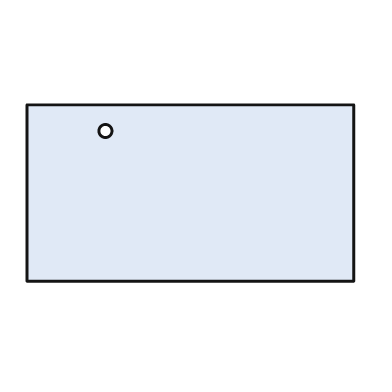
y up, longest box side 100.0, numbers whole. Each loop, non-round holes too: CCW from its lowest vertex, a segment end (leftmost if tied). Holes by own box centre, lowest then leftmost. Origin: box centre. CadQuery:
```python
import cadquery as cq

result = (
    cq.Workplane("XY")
    .moveTo(-50.0, -27.0)
    .lineTo(50.0, -27.0)
    .lineTo(50.0, 27.0)
    .lineTo(-50.0, 27.0)
    .close()
    .moveTo(-26.0, 19.0)
    .circle(2.0)
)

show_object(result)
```